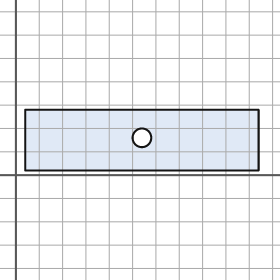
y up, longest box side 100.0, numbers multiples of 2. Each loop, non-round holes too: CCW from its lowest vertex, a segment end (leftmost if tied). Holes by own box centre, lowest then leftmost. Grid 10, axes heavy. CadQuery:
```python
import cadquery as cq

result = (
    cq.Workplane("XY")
    .moveTo(4.0, 2.0)
    .lineTo(104.0, 2.0)
    .lineTo(104.0, 28.0)
    .lineTo(4.0, 28.0)
    .close()
    .moveTo(54.0, 16.0)
    .circle(4.0)
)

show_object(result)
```